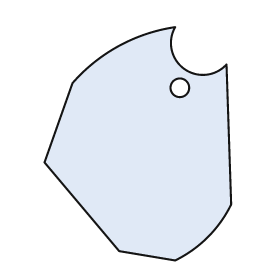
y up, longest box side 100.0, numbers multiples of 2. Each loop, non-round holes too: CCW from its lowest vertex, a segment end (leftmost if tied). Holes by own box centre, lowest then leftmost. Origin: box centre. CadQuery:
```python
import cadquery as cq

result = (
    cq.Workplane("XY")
    .moveTo(16.0, -50.0)
    .threePointArc((30.0, -40.0), (40.0, -26.0))
    .lineTo(38.0, 34.0)
    .threePointArc((20.0, 32.0), (16.0, 50.0))
    .threePointArc((-8.0, 42.0), (-28.0, 26.0))
    .lineTo(-40.0, -8.0)
    .lineTo(-8.0, -46.0)
    .close()
    .moveTo(18.0, 24.0)
    .circle(4.0)
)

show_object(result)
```